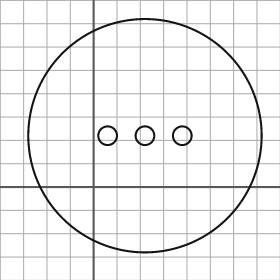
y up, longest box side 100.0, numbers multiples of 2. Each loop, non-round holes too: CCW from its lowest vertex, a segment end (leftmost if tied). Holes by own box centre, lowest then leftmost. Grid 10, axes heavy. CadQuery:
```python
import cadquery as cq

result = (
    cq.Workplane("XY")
    .moveTo(22.0, 22.0)
    .circle(50.0)
    .moveTo(6.0, 22.0)
    .circle(4.0)
    .moveTo(22.0, 22.0)
    .circle(4.0)
    .moveTo(38.0, 22.0)
    .circle(4.0)
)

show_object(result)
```